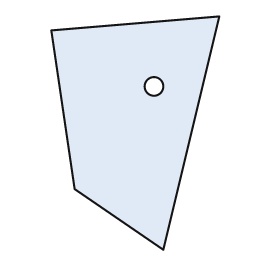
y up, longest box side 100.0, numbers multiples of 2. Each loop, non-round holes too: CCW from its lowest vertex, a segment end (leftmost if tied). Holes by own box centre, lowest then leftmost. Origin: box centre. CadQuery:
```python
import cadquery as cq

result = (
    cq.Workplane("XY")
    .moveTo(12.0, -50.0)
    .lineTo(36.0, 50.0)
    .lineTo(-36.0, 44.0)
    .lineTo(-26.0, -24.0)
    .close()
    .moveTo(8.0, 20.0)
    .circle(4.0)
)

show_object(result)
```